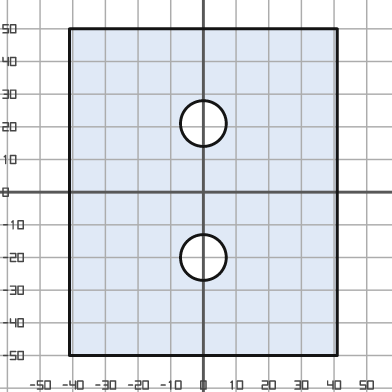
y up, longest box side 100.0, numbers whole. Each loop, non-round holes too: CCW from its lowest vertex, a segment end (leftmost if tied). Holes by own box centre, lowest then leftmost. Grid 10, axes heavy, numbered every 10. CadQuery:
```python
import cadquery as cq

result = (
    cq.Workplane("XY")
    .moveTo(-41.0, -50.0)
    .lineTo(41.0, -50.0)
    .lineTo(41.0, 50.0)
    .lineTo(-41.0, 50.0)
    .close()
    .moveTo(0.0, -20.0)
    .circle(7.0)
    .moveTo(0.0, 21.0)
    .circle(7.0)
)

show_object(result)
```